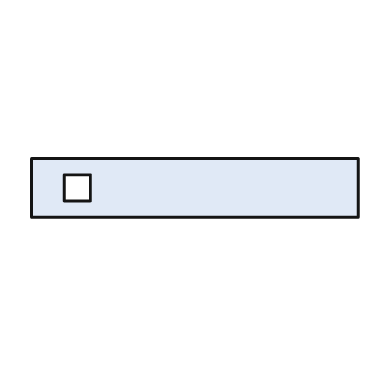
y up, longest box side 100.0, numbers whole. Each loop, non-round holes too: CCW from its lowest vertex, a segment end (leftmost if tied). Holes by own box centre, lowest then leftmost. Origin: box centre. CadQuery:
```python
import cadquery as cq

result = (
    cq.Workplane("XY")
    .moveTo(-50.0, -9.0)
    .lineTo(50.0, -9.0)
    .lineTo(50.0, 9.0)
    .lineTo(-50.0, 9.0)
    .close()
    .moveTo(-40.0, -4.0)
    .lineTo(-32.0, -4.0)
    .lineTo(-32.0, 4.0)
    .lineTo(-40.0, 4.0)
    .close()
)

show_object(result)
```